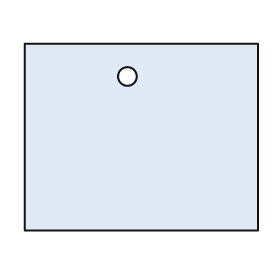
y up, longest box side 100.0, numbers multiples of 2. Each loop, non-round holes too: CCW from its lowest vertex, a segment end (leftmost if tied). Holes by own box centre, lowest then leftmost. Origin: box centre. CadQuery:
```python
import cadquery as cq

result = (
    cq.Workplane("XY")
    .moveTo(-50.0, -40.0)
    .lineTo(50.0, -40.0)
    .lineTo(50.0, 40.0)
    .lineTo(-50.0, 40.0)
    .close()
    .moveTo(-6.0, 26.0)
    .circle(4.0)
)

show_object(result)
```